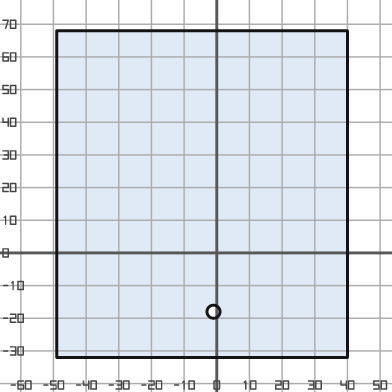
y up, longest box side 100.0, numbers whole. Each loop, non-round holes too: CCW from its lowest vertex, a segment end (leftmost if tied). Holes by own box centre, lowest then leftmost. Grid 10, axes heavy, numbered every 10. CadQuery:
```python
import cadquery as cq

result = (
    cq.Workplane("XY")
    .moveTo(-49.0, -32.0)
    .lineTo(40.0, -32.0)
    .lineTo(40.0, 68.0)
    .lineTo(-49.0, 68.0)
    .close()
    .moveTo(-1.0, -18.0)
    .circle(2.0)
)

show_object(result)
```